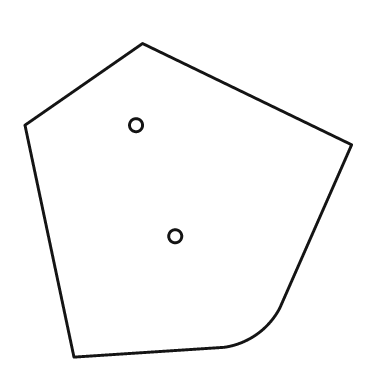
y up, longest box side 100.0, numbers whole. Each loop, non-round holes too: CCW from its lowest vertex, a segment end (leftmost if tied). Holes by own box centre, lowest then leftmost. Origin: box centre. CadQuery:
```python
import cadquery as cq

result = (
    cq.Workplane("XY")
    .moveTo(-35.0, -48.0)
    .lineTo(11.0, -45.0)
    .threePointArc((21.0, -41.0), (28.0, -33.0))
    .lineTo(50.0, 17.0)
    .lineTo(-14.0, 48.0)
    .lineTo(-50.0, 23.0)
    .close()
    .moveTo(-4.0, -11.0)
    .circle(2.0)
    .moveTo(-16.0, 23.0)
    .circle(2.0)
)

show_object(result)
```